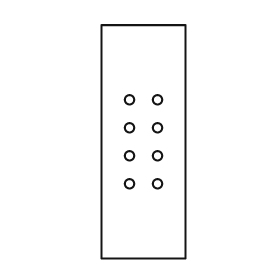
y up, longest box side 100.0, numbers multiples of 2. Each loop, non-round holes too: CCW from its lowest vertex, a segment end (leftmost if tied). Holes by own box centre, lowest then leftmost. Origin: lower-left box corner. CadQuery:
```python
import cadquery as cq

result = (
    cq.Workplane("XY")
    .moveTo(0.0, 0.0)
    .lineTo(36.0, 0.0)
    .lineTo(36.0, 100.0)
    .lineTo(0.0, 100.0)
    .close()
    .moveTo(12.0, 32.0)
    .circle(2.0)
    .moveTo(24.0, 32.0)
    .circle(2.0)
    .moveTo(12.0, 44.0)
    .circle(2.0)
    .moveTo(24.0, 44.0)
    .circle(2.0)
    .moveTo(12.0, 56.0)
    .circle(2.0)
    .moveTo(24.0, 56.0)
    .circle(2.0)
    .moveTo(12.0, 68.0)
    .circle(2.0)
    .moveTo(24.0, 68.0)
    .circle(2.0)
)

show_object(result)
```